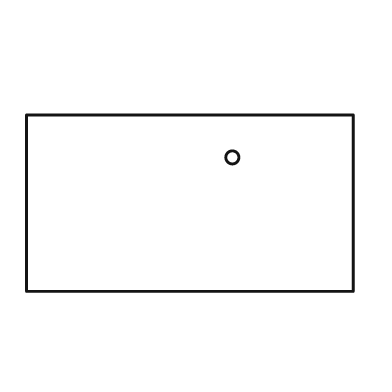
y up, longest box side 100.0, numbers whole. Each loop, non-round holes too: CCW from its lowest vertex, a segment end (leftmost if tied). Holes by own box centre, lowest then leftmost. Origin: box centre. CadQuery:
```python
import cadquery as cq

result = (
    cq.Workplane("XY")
    .moveTo(-50.0, -27.0)
    .lineTo(50.0, -27.0)
    .lineTo(50.0, 27.0)
    .lineTo(-50.0, 27.0)
    .close()
    .moveTo(13.0, 14.0)
    .circle(2.0)
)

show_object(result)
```